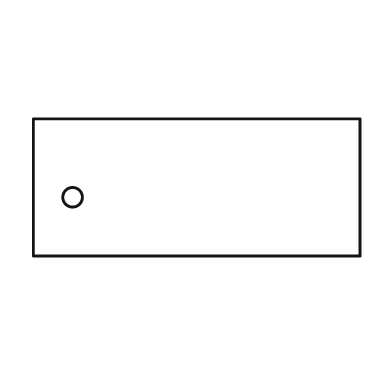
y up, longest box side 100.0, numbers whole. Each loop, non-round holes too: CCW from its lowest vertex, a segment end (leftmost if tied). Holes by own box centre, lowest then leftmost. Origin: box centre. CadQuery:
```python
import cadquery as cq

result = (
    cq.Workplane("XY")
    .moveTo(-50.0, -21.0)
    .lineTo(50.0, -21.0)
    .lineTo(50.0, 21.0)
    .lineTo(-50.0, 21.0)
    .close()
    .moveTo(-38.0, -3.0)
    .circle(3.0)
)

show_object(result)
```